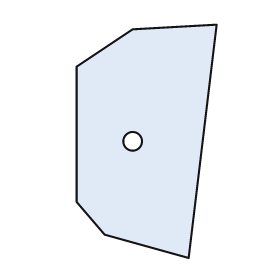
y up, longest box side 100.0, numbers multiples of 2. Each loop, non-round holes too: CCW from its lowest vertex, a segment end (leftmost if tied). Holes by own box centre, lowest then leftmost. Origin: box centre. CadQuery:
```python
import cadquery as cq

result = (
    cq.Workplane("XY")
    .moveTo(18.0, -50.0)
    .lineTo(30.0, 50.0)
    .lineTo(-6.0, 48.0)
    .lineTo(-30.0, 32.0)
    .lineTo(-30.0, -26.0)
    .lineTo(-18.0, -40.0)
    .close()
    .moveTo(-6.0, 0.0)
    .circle(4.0)
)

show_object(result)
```